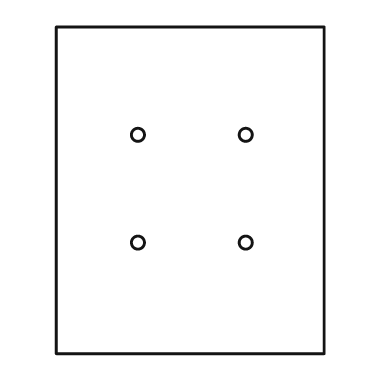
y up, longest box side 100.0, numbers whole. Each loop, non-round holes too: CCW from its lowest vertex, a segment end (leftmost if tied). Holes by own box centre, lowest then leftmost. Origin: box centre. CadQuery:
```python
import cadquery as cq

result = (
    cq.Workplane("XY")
    .moveTo(-41.0, -50.0)
    .lineTo(41.0, -50.0)
    .lineTo(41.0, 50.0)
    .lineTo(-41.0, 50.0)
    .close()
    .moveTo(-16.0, -16.0)
    .circle(2.0)
    .moveTo(17.0, -16.0)
    .circle(2.0)
    .moveTo(-16.0, 17.0)
    .circle(2.0)
    .moveTo(17.0, 17.0)
    .circle(2.0)
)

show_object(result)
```